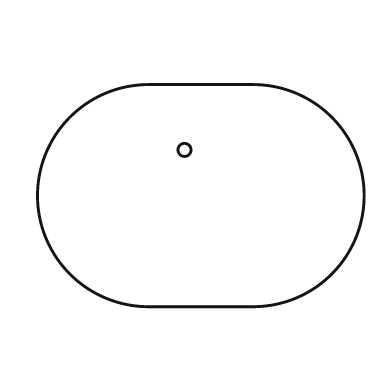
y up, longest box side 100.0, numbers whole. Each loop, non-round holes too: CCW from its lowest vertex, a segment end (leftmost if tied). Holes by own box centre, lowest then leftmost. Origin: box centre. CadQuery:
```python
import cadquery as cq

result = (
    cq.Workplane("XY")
    .moveTo(-16.0, -34.0)
    .lineTo(16.0, -34.0)
    .threePointArc((50.0, 0.0), (16.0, 34.0))
    .lineTo(-16.0, 34.0)
    .threePointArc((-50.0, 0.0), (-16.0, -34.0))
    .close()
    .moveTo(-5.0, 14.0)
    .circle(2.0)
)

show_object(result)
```